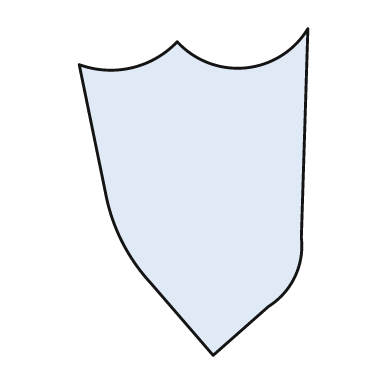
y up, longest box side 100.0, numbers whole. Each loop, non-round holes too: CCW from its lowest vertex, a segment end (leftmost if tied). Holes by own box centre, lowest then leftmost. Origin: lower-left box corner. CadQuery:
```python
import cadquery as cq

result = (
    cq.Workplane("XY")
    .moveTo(41.0, 0.0)
    .lineTo(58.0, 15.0)
    .threePointArc((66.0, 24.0), (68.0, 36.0))
    .lineTo(70.0, 100.0)
    .threePointArc((51.0, 88.0), (30.0, 96.0))
    .threePointArc((16.0, 88.0), (0.0, 89.0))
    .lineTo(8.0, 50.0)
    .threePointArc((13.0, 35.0), (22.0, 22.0))
    .close()
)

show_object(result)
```